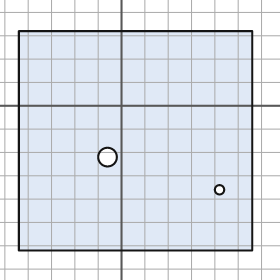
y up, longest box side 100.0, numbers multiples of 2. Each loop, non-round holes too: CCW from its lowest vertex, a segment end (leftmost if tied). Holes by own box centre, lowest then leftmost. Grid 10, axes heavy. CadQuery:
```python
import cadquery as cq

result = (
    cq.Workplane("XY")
    .moveTo(-44.0, -62.0)
    .lineTo(56.0, -62.0)
    .lineTo(56.0, 32.0)
    .lineTo(-44.0, 32.0)
    .close()
    .moveTo(42.0, -36.0)
    .circle(2.0)
    .moveTo(-6.0, -22.0)
    .circle(4.0)
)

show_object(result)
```